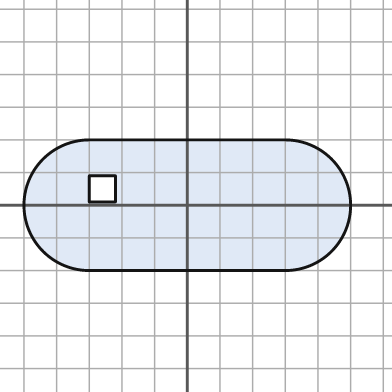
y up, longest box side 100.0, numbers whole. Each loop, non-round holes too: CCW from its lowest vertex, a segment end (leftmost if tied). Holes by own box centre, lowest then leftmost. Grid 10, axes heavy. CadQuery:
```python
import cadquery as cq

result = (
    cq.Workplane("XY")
    .moveTo(-30.0, -20.0)
    .lineTo(30.0, -20.0)
    .threePointArc((50.0, 0.0), (30.0, 20.0))
    .lineTo(-30.0, 20.0)
    .threePointArc((-50.0, 0.0), (-30.0, -20.0))
    .close()
    .moveTo(-30.0, 1.0)
    .lineTo(-22.0, 1.0)
    .lineTo(-22.0, 9.0)
    .lineTo(-30.0, 9.0)
    .close()
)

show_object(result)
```